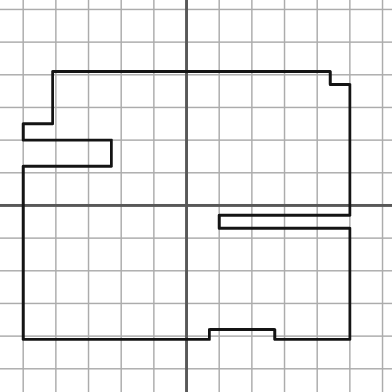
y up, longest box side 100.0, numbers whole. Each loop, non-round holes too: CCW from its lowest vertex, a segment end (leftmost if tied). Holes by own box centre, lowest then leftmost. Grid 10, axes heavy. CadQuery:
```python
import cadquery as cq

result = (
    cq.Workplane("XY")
    .moveTo(-50.0, -41.0)
    .lineTo(7.0, -41.0)
    .lineTo(7.0, -38.0)
    .lineTo(27.0, -38.0)
    .lineTo(27.0, -41.0)
    .lineTo(50.0, -41.0)
    .lineTo(50.0, -7.0)
    .lineTo(10.0, -7.0)
    .lineTo(10.0, -3.0)
    .lineTo(50.0, -3.0)
    .lineTo(50.0, 37.0)
    .lineTo(44.0, 37.0)
    .lineTo(44.0, 41.0)
    .lineTo(-41.0, 41.0)
    .lineTo(-41.0, 25.0)
    .lineTo(-50.0, 25.0)
    .lineTo(-50.0, 20.0)
    .lineTo(-23.0, 20.0)
    .lineTo(-23.0, 12.0)
    .lineTo(-50.0, 12.0)
    .close()
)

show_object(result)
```